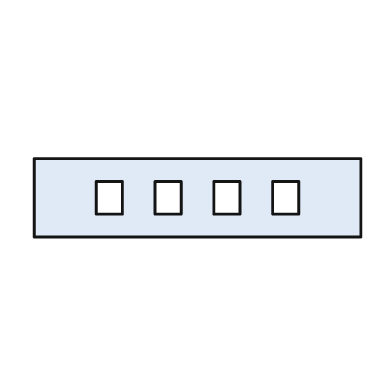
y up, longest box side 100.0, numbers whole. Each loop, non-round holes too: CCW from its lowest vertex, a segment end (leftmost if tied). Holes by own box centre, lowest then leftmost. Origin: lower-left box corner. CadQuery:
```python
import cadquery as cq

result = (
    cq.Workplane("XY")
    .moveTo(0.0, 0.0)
    .lineTo(100.0, 0.0)
    .lineTo(100.0, 24.0)
    .lineTo(0.0, 24.0)
    .close()
    .moveTo(19.0, 7.0)
    .lineTo(27.0, 7.0)
    .lineTo(27.0, 17.0)
    .lineTo(19.0, 17.0)
    .close()
    .moveTo(37.0, 7.0)
    .lineTo(45.0, 7.0)
    .lineTo(45.0, 17.0)
    .lineTo(37.0, 17.0)
    .close()
    .moveTo(55.0, 7.0)
    .lineTo(63.0, 7.0)
    .lineTo(63.0, 17.0)
    .lineTo(55.0, 17.0)
    .close()
    .moveTo(73.0, 7.0)
    .lineTo(81.0, 7.0)
    .lineTo(81.0, 17.0)
    .lineTo(73.0, 17.0)
    .close()
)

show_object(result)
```